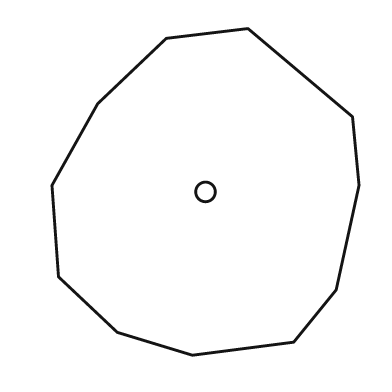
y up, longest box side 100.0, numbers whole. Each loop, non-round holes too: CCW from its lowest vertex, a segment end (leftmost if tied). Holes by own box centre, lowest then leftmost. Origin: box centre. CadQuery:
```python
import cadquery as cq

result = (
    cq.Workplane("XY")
    .moveTo(-4.0, -50.0)
    .lineTo(27.0, -46.0)
    .lineTo(40.0, -30.0)
    .lineTo(47.0, 2.0)
    .lineTo(45.0, 23.0)
    .lineTo(13.0, 50.0)
    .lineTo(-12.0, 47.0)
    .lineTo(-33.0, 27.0)
    .lineTo(-47.0, 2.0)
    .lineTo(-45.0, -26.0)
    .lineTo(-27.0, -43.0)
    .close()
    .moveTo(0.0, 0.0)
    .circle(3.0)
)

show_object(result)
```